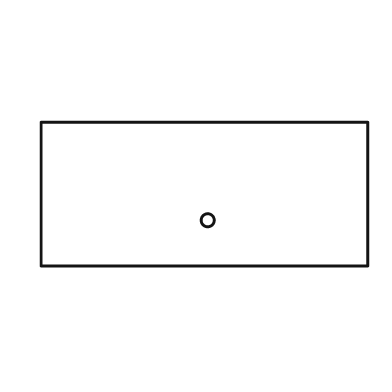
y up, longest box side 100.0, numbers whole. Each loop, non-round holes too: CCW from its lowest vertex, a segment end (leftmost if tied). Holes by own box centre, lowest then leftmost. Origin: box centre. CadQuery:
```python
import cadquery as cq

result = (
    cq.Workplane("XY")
    .moveTo(-50.0, -22.0)
    .lineTo(50.0, -22.0)
    .lineTo(50.0, 22.0)
    .lineTo(-50.0, 22.0)
    .close()
    .moveTo(1.0, -8.0)
    .circle(2.0)
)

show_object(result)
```